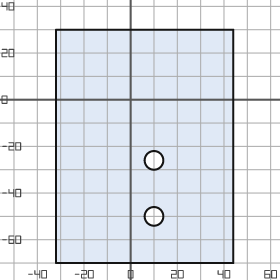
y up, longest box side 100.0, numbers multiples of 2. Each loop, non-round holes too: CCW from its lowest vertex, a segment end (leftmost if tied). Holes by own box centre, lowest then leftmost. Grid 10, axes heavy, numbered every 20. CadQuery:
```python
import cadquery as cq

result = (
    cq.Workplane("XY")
    .moveTo(-32.0, -70.0)
    .lineTo(44.0, -70.0)
    .lineTo(44.0, 30.0)
    .lineTo(-32.0, 30.0)
    .close()
    .moveTo(10.0, -50.0)
    .circle(4.0)
    .moveTo(10.0, -26.0)
    .circle(4.0)
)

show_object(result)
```